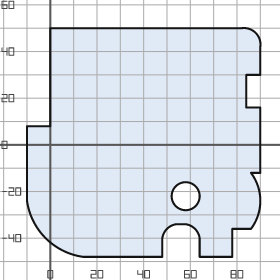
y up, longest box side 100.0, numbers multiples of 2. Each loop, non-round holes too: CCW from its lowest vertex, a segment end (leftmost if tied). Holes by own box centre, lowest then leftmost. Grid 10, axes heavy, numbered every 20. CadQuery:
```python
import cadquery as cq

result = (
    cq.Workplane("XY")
    .moveTo(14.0, -48.0)
    .lineTo(48.0, -48.0)
    .lineTo(48.0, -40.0)
    .threePointArc((50.0, -36.0), (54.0, -34.0))
    .lineTo(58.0, -34.0)
    .threePointArc((62.0, -36.0), (64.0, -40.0))
    .lineTo(64.0, -48.0)
    .lineTo(78.0, -48.0)
    .lineTo(78.0, -36.0)
    .lineTo(86.0, -36.0)
    .threePointArc((90.0, -24.0), (86.0, -12.0))
    .lineTo(90.0, -12.0)
    .lineTo(90.0, 16.0)
    .lineTo(84.0, 16.0)
    .lineTo(84.0, 30.0)
    .lineTo(90.0, 30.0)
    .lineTo(90.0, 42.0)
    .threePointArc((88.0, 48.0), (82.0, 50.0))
    .lineTo(0.0, 50.0)
    .lineTo(0.0, 8.0)
    .lineTo(-10.0, 8.0)
    .lineTo(-10.0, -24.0)
    .threePointArc((-2.0, -40.0), (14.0, -48.0))
    .close()
    .moveTo(58.0, -22.0)
    .circle(6.0)
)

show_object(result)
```